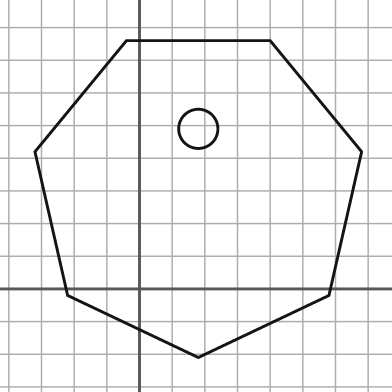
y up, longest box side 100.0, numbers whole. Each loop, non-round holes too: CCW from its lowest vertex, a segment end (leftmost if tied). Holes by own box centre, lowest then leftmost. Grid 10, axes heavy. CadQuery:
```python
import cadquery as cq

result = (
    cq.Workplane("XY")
    .moveTo(18.0, -21.0)
    .lineTo(58.0, -2.0)
    .lineTo(68.0, 42.0)
    .lineTo(40.0, 76.0)
    .lineTo(-4.0, 76.0)
    .lineTo(-32.0, 42.0)
    .lineTo(-22.0, -2.0)
    .close()
    .moveTo(18.0, 49.0)
    .circle(6.0)
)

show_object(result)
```